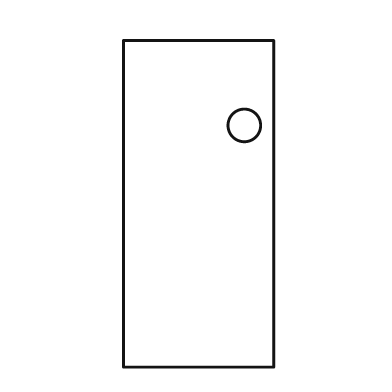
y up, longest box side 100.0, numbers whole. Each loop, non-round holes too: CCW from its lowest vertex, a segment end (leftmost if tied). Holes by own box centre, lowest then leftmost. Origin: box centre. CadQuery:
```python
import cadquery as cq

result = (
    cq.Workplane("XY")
    .moveTo(-23.0, -50.0)
    .lineTo(23.0, -50.0)
    .lineTo(23.0, 50.0)
    .lineTo(-23.0, 50.0)
    .close()
    .moveTo(14.0, 24.0)
    .circle(5.0)
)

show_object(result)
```